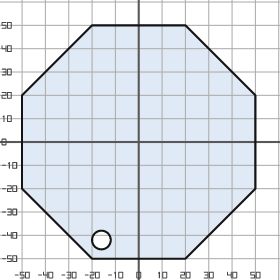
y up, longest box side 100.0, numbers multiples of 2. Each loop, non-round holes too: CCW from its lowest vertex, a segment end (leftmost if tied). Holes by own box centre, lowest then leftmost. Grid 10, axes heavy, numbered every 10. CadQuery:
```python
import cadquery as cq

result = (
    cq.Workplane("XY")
    .moveTo(-20.0, -50.0)
    .lineTo(20.0, -50.0)
    .lineTo(50.0, -20.0)
    .lineTo(50.0, 20.0)
    .lineTo(20.0, 50.0)
    .lineTo(-20.0, 50.0)
    .lineTo(-50.0, 20.0)
    .lineTo(-50.0, -20.0)
    .close()
    .moveTo(-16.0, -42.0)
    .circle(4.0)
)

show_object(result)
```